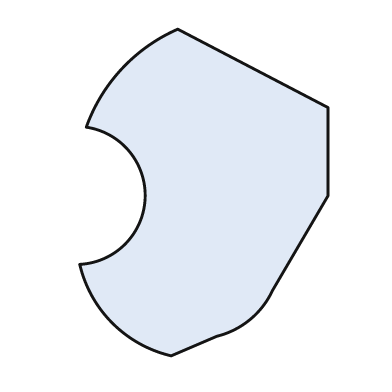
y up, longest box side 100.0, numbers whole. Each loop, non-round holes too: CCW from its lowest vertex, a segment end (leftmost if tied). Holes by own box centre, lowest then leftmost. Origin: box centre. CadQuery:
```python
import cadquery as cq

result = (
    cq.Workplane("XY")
    .moveTo(-10.0, -50.0)
    .lineTo(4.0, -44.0)
    .threePointArc((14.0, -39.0), (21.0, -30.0))
    .lineTo(38.0, -1.0)
    .lineTo(38.0, 26.0)
    .lineTo(-8.0, 50.0)
    .threePointArc((-25.0, 38.0), (-36.0, 20.0))
    .threePointArc((-18.0, -2.0), (-38.0, -22.0))
    .threePointArc((-28.0, -40.0), (-10.0, -50.0))
    .close()
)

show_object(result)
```